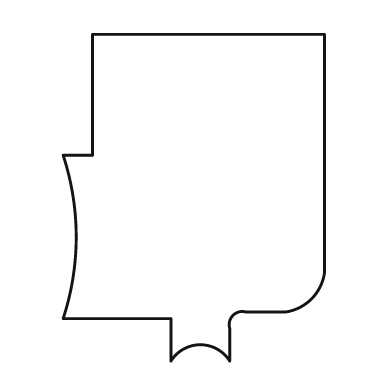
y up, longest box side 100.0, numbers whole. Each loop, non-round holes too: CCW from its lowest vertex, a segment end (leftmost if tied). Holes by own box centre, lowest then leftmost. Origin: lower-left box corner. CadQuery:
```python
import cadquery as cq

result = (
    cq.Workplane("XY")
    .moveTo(33.0, 0.0)
    .threePointArc((42.0, 5.0), (51.0, 0.0))
    .lineTo(51.0, 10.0)
    .threePointArc((52.0, 14.0), (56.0, 15.0))
    .lineTo(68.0, 15.0)
    .threePointArc((76.0, 19.0), (80.0, 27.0))
    .lineTo(80.0, 100.0)
    .lineTo(9.0, 100.0)
    .lineTo(9.0, 63.0)
    .lineTo(0.0, 63.0)
    .threePointArc((4.0, 38.0), (0.0, 13.0))
    .lineTo(33.0, 13.0)
    .close()
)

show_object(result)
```